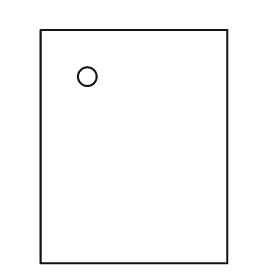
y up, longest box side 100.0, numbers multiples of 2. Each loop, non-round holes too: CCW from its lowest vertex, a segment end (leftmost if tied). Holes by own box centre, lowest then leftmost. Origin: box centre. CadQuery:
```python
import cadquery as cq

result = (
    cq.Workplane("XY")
    .moveTo(-40.0, -50.0)
    .lineTo(40.0, -50.0)
    .lineTo(40.0, 50.0)
    .lineTo(-40.0, 50.0)
    .close()
    .moveTo(-20.0, 30.0)
    .circle(4.0)
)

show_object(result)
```